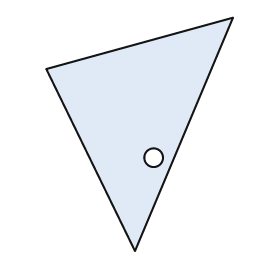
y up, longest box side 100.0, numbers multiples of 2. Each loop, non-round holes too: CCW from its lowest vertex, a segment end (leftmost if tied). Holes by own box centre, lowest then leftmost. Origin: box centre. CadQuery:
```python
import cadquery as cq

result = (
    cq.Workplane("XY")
    .moveTo(-2.0, -50.0)
    .lineTo(40.0, 50.0)
    .lineTo(-40.0, 28.0)
    .close()
    .moveTo(6.0, -10.0)
    .circle(4.0)
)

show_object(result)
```